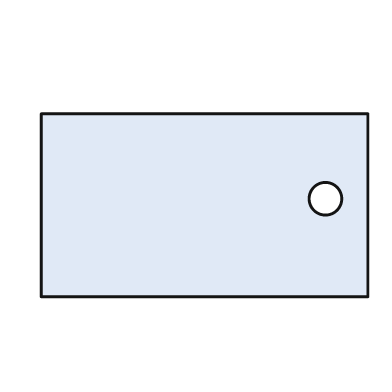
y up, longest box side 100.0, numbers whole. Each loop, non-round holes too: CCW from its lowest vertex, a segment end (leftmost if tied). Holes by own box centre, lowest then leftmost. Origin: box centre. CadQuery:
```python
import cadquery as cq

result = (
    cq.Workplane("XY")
    .moveTo(-50.0, -28.0)
    .lineTo(50.0, -28.0)
    .lineTo(50.0, 28.0)
    .lineTo(-50.0, 28.0)
    .close()
    .moveTo(37.0, 2.0)
    .circle(5.0)
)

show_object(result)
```